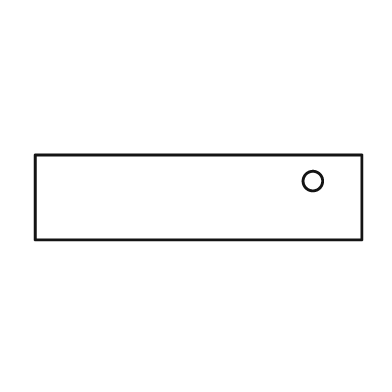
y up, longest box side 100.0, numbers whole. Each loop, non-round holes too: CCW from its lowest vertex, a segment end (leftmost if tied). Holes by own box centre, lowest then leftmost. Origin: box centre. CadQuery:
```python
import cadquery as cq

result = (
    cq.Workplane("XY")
    .moveTo(-50.0, -13.0)
    .lineTo(50.0, -13.0)
    .lineTo(50.0, 13.0)
    .lineTo(-50.0, 13.0)
    .close()
    .moveTo(35.0, 5.0)
    .circle(3.0)
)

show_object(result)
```